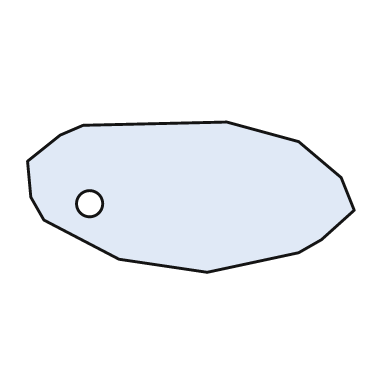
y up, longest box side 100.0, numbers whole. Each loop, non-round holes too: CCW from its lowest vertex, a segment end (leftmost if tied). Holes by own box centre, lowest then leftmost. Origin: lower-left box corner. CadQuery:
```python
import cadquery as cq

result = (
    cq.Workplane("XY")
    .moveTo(55.0, 0.0)
    .lineTo(83.0, 6.0)
    .lineTo(90.0, 10.0)
    .lineTo(100.0, 19.0)
    .lineTo(96.0, 29.0)
    .lineTo(83.0, 40.0)
    .lineTo(61.0, 46.0)
    .lineTo(17.0, 45.0)
    .lineTo(10.0, 42.0)
    .lineTo(0.0, 34.0)
    .lineTo(1.0, 23.0)
    .lineTo(5.0, 16.0)
    .lineTo(28.0, 4.0)
    .close()
    .moveTo(19.0, 21.0)
    .circle(4.0)
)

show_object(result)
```